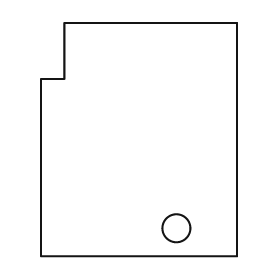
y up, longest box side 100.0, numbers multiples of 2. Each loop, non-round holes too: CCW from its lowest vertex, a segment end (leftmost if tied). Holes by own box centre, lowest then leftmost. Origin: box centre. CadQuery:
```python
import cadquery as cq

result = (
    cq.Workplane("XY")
    .moveTo(-42.0, -50.0)
    .lineTo(42.0, -50.0)
    .lineTo(42.0, 50.0)
    .lineTo(-32.0, 50.0)
    .lineTo(-32.0, 26.0)
    .lineTo(-42.0, 26.0)
    .close()
    .moveTo(16.0, -38.0)
    .circle(6.0)
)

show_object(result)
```